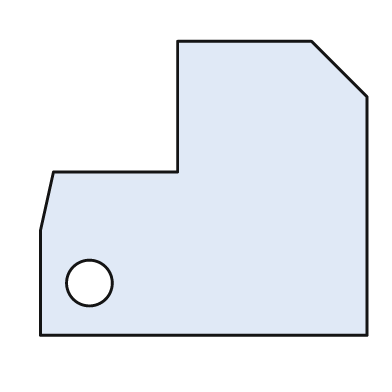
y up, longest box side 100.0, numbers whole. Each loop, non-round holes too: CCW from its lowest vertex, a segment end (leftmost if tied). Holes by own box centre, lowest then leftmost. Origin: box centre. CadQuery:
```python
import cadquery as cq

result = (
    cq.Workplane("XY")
    .moveTo(-50.0, -45.0)
    .lineTo(50.0, -45.0)
    .lineTo(50.0, 28.0)
    .lineTo(33.0, 45.0)
    .lineTo(-8.0, 45.0)
    .lineTo(-8.0, 5.0)
    .lineTo(-46.0, 5.0)
    .lineTo(-50.0, -13.0)
    .close()
    .moveTo(-35.0, -29.0)
    .circle(7.0)
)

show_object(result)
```